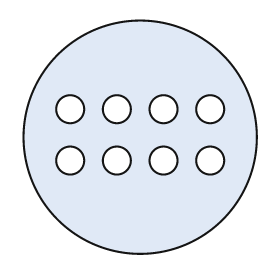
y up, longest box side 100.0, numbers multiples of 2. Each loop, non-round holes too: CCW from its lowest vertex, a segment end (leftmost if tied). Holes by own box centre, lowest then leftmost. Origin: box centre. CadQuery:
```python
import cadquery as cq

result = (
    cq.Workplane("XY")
    .moveTo(0.0, 0.0)
    .circle(50.0)
    .moveTo(-30.0, -10.0)
    .circle(6.0)
    .moveTo(-10.0, -10.0)
    .circle(6.0)
    .moveTo(10.0, -10.0)
    .circle(6.0)
    .moveTo(30.0, -10.0)
    .circle(6.0)
    .moveTo(-30.0, 12.0)
    .circle(6.0)
    .moveTo(-10.0, 12.0)
    .circle(6.0)
    .moveTo(10.0, 12.0)
    .circle(6.0)
    .moveTo(30.0, 12.0)
    .circle(6.0)
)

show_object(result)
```